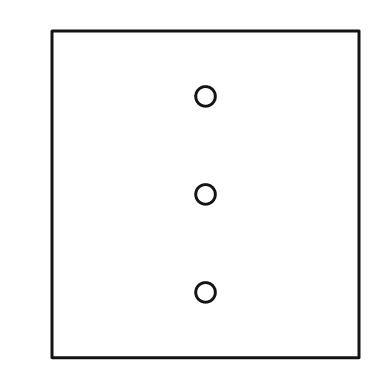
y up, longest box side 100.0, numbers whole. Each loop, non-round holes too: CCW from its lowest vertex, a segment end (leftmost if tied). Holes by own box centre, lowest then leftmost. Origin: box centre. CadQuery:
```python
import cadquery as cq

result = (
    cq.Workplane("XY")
    .moveTo(-47.0, -50.0)
    .lineTo(47.0, -50.0)
    .lineTo(47.0, 50.0)
    .lineTo(-47.0, 50.0)
    .close()
    .moveTo(0.0, -30.0)
    .circle(3.0)
    .moveTo(0.0, 0.0)
    .circle(3.0)
    .moveTo(0.0, 30.0)
    .circle(3.0)
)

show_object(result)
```